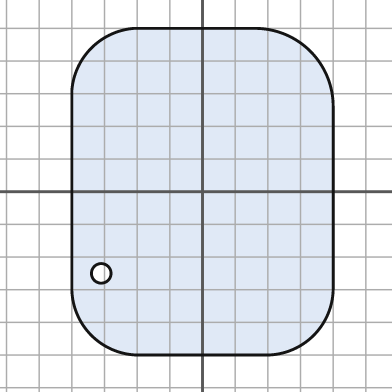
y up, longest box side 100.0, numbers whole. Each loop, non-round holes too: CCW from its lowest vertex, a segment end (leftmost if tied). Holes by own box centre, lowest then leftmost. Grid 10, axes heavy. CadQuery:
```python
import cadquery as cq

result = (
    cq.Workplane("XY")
    .moveTo(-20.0, -50.0)
    .lineTo(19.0, -50.0)
    .threePointArc((34.0, -44.0), (40.0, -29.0))
    .lineTo(40.0, 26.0)
    .threePointArc((33.0, 43.0), (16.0, 50.0))
    .lineTo(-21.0, 50.0)
    .threePointArc((-34.0, 44.0), (-40.0, 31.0))
    .lineTo(-40.0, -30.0)
    .threePointArc((-34.0, -44.0), (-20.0, -50.0))
    .close()
    .moveTo(-31.0, -25.0)
    .circle(3.0)
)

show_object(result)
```